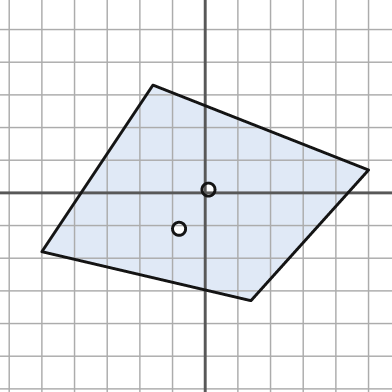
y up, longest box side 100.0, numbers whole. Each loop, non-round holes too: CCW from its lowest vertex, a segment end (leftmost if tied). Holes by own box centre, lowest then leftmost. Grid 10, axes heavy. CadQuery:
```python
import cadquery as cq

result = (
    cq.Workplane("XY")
    .moveTo(14.0, -33.0)
    .lineTo(50.0, 7.0)
    .lineTo(-16.0, 33.0)
    .lineTo(-50.0, -18.0)
    .close()
    .moveTo(-8.0, -11.0)
    .circle(2.0)
    .moveTo(1.0, 1.0)
    .circle(2.0)
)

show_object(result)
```